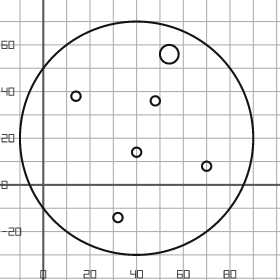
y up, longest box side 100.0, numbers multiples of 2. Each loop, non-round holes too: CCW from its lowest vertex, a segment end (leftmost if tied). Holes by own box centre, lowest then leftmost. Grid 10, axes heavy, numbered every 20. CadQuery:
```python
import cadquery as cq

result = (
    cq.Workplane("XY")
    .moveTo(40.0, 20.0)
    .circle(50.0)
    .moveTo(32.0, -14.0)
    .circle(2.0)
    .moveTo(70.0, 8.0)
    .circle(2.0)
    .moveTo(40.0, 14.0)
    .circle(2.0)
    .moveTo(48.0, 36.0)
    .circle(2.0)
    .moveTo(14.0, 38.0)
    .circle(2.0)
    .moveTo(54.0, 56.0)
    .circle(4.0)
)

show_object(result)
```